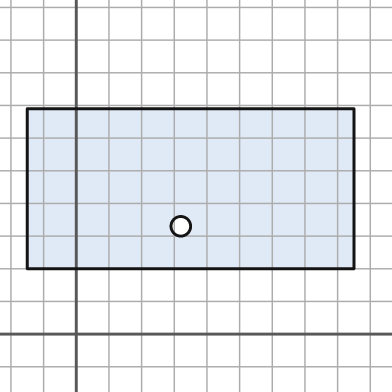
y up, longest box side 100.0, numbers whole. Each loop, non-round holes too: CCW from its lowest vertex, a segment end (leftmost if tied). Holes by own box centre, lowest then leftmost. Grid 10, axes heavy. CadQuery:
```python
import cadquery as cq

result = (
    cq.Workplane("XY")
    .moveTo(-15.0, 20.0)
    .lineTo(85.0, 20.0)
    .lineTo(85.0, 69.0)
    .lineTo(-15.0, 69.0)
    .close()
    .moveTo(32.0, 33.0)
    .circle(3.0)
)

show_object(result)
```